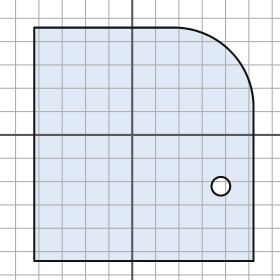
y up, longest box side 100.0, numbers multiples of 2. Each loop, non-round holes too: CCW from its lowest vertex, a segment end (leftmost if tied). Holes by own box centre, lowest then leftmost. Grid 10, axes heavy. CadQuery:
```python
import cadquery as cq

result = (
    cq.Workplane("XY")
    .moveTo(-42.0, -54.0)
    .lineTo(52.0, -54.0)
    .lineTo(52.0, 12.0)
    .threePointArc((42.0, 36.0), (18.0, 46.0))
    .lineTo(-42.0, 46.0)
    .close()
    .moveTo(38.0, -22.0)
    .circle(4.0)
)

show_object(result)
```